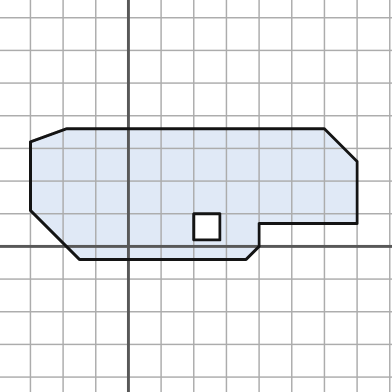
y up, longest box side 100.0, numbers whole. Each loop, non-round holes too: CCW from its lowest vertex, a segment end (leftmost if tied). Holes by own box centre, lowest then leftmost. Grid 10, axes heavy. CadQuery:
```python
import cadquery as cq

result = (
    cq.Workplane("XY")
    .moveTo(-15.0, -4.0)
    .lineTo(36.0, -4.0)
    .lineTo(40.0, 0.0)
    .lineTo(40.0, 7.0)
    .lineTo(70.0, 7.0)
    .lineTo(70.0, 26.0)
    .lineTo(60.0, 36.0)
    .lineTo(-19.0, 36.0)
    .lineTo(-30.0, 32.0)
    .lineTo(-30.0, 11.0)
    .close()
    .moveTo(20.0, 2.0)
    .lineTo(28.0, 2.0)
    .lineTo(28.0, 10.0)
    .lineTo(20.0, 10.0)
    .close()
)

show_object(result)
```